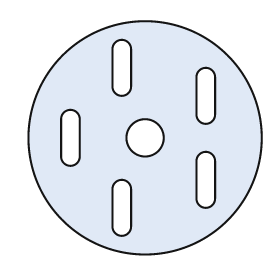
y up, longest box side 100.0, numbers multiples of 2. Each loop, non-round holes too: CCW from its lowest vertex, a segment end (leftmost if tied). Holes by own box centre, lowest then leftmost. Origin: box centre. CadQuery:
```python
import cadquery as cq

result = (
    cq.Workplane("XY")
    .moveTo(0.0, 0.0)
    .circle(50.0)
    .moveTo(-14.0, -38.0)
    .threePointArc((-10.0, -42.0), (-6.0, -38.0))
    .lineTo(-6.0, -22.0)
    .threePointArc((-10.0, -18.0), (-14.0, -22.0))
    .close()
    .moveTo(22.0, -26.0)
    .threePointArc((26.0, -30.0), (30.0, -26.0))
    .lineTo(30.0, -10.0)
    .threePointArc((26.0, -6.0), (22.0, -10.0))
    .close()
    .moveTo(-36.0, -8.0)
    .threePointArc((-32.0, -12.0), (-28.0, -8.0))
    .lineTo(-28.0, 8.0)
    .threePointArc((-32.0, 12.0), (-36.0, 8.0))
    .close()
    .moveTo(0.0, 0.0)
    .circle(8.0)
    .moveTo(22.0, 10.0)
    .threePointArc((26.0, 6.0), (30.0, 10.0))
    .lineTo(30.0, 26.0)
    .threePointArc((26.0, 30.0), (22.0, 26.0))
    .close()
    .moveTo(-14.0, 22.0)
    .threePointArc((-10.0, 18.0), (-6.0, 22.0))
    .lineTo(-6.0, 38.0)
    .threePointArc((-10.0, 42.0), (-14.0, 38.0))
    .close()
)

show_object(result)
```